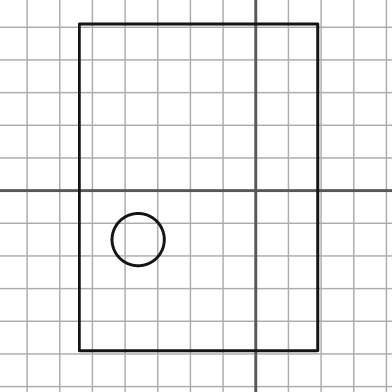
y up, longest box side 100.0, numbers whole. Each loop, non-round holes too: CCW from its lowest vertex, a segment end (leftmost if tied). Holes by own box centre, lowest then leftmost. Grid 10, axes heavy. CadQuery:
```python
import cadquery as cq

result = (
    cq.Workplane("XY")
    .moveTo(-54.0, -49.0)
    .lineTo(19.0, -49.0)
    .lineTo(19.0, 51.0)
    .lineTo(-54.0, 51.0)
    .close()
    .moveTo(-36.0, -15.0)
    .circle(8.0)
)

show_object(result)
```